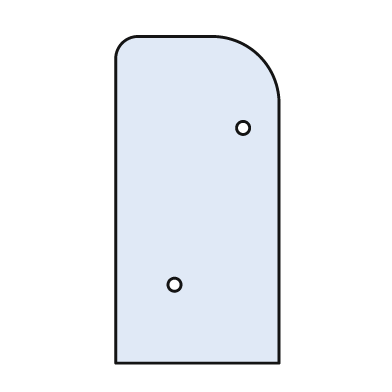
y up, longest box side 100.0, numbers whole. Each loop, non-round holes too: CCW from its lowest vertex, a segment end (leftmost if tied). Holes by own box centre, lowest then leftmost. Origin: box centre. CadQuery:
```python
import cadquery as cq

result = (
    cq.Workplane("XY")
    .moveTo(-25.0, -50.0)
    .lineTo(25.0, -50.0)
    .lineTo(25.0, 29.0)
    .threePointArc((19.0, 44.0), (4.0, 50.0))
    .lineTo(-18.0, 50.0)
    .threePointArc((-23.0, 48.0), (-25.0, 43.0))
    .close()
    .moveTo(-7.0, -26.0)
    .circle(2.0)
    .moveTo(14.0, 22.0)
    .circle(2.0)
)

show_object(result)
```